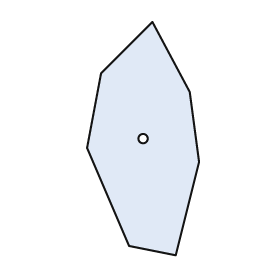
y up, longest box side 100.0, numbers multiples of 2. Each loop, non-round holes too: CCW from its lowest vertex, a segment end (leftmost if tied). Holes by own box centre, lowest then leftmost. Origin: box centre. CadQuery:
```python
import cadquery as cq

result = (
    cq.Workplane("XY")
    .moveTo(14.0, -50.0)
    .lineTo(24.0, -10.0)
    .lineTo(20.0, 20.0)
    .lineTo(4.0, 50.0)
    .lineTo(-18.0, 28.0)
    .lineTo(-24.0, -4.0)
    .lineTo(-6.0, -46.0)
    .close()
    .moveTo(0.0, 0.0)
    .circle(2.0)
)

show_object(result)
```